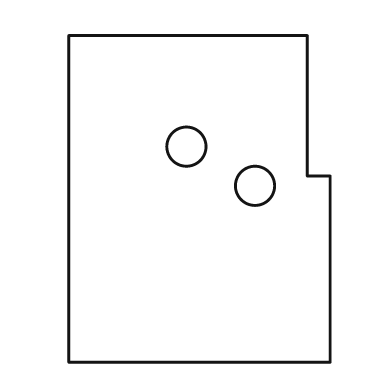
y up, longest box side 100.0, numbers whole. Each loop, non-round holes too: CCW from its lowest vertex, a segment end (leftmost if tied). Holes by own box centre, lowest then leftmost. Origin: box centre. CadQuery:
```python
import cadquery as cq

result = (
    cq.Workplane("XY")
    .moveTo(-40.0, -50.0)
    .lineTo(40.0, -50.0)
    .lineTo(40.0, 7.0)
    .lineTo(33.0, 7.0)
    .lineTo(33.0, 50.0)
    .lineTo(-40.0, 50.0)
    .close()
    .moveTo(17.0, 4.0)
    .circle(6.0)
    .moveTo(-4.0, 16.0)
    .circle(6.0)
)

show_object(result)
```